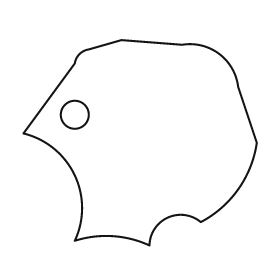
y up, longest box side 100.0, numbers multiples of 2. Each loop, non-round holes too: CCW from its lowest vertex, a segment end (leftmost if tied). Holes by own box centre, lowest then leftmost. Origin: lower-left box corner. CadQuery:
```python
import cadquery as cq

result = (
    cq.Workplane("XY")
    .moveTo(54.0, 0.0)
    .threePointArc((62.0, 12.0), (76.0, 10.0))
    .threePointArc((92.0, 24.0), (100.0, 44.0))
    .lineTo(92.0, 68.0)
    .threePointArc((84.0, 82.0), (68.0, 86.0))
    .lineTo(42.0, 88.0)
    .lineTo(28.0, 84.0)
    .threePointArc((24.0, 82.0), (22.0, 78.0))
    .lineTo(0.0, 48.0)
    .threePointArc((22.0, 30.0), (22.0, 2.0))
    .threePointArc((38.0, 4.0), (54.0, 0.0))
    .close()
    .moveTo(22.0, 56.0)
    .circle(6.0)
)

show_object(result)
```